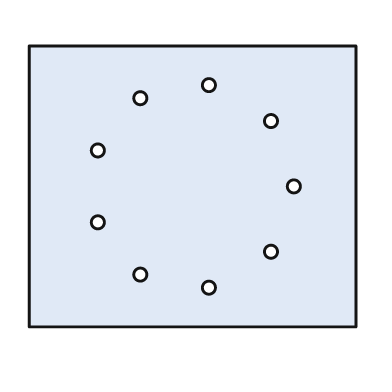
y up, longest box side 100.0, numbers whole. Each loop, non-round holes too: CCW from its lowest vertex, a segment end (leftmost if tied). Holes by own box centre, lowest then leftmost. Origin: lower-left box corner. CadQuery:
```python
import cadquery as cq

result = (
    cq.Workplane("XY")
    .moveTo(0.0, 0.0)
    .lineTo(100.0, 0.0)
    .lineTo(100.0, 86.0)
    .lineTo(0.0, 86.0)
    .close()
    .moveTo(55.0, 12.0)
    .circle(2.0)
    .moveTo(34.0, 16.0)
    .circle(2.0)
    .moveTo(74.0, 23.0)
    .circle(2.0)
    .moveTo(21.0, 32.0)
    .circle(2.0)
    .moveTo(81.0, 43.0)
    .circle(2.0)
    .moveTo(21.0, 54.0)
    .circle(2.0)
    .moveTo(74.0, 63.0)
    .circle(2.0)
    .moveTo(34.0, 70.0)
    .circle(2.0)
    .moveTo(55.0, 74.0)
    .circle(2.0)
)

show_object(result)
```